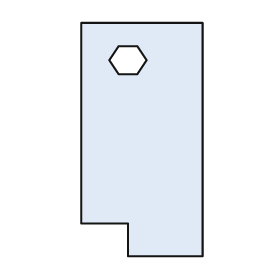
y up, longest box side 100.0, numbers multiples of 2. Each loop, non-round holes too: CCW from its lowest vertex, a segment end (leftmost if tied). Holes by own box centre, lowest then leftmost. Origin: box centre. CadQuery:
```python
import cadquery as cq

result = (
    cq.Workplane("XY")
    .moveTo(-6.0, -50.0)
    .lineTo(26.0, -50.0)
    .lineTo(26.0, 50.0)
    .lineTo(-26.0, 50.0)
    .lineTo(-26.0, -36.0)
    .lineTo(-6.0, -36.0)
    .close()
    .moveTo(-10.0, 28.0)
    .lineTo(-2.0, 28.0)
    .lineTo(2.0, 34.0)
    .lineTo(-2.0, 40.0)
    .lineTo(-10.0, 40.0)
    .lineTo(-14.0, 34.0)
    .close()
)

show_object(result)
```